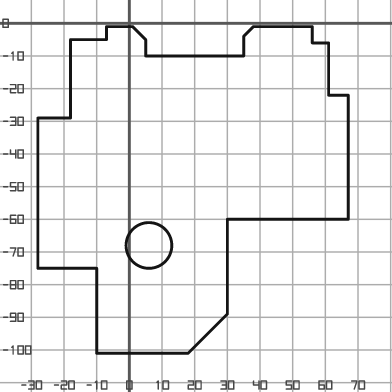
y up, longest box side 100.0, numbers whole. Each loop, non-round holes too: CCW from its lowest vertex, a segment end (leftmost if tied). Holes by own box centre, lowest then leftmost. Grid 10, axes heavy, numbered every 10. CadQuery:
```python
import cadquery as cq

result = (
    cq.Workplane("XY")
    .moveTo(-10.0, -101.0)
    .lineTo(18.0, -101.0)
    .lineTo(30.0, -89.0)
    .lineTo(30.0, -60.0)
    .lineTo(67.0, -60.0)
    .lineTo(67.0, -22.0)
    .lineTo(61.0, -22.0)
    .lineTo(61.0, -6.0)
    .lineTo(56.0, -6.0)
    .lineTo(56.0, -1.0)
    .lineTo(38.0, -1.0)
    .lineTo(35.0, -4.0)
    .lineTo(35.0, -10.0)
    .lineTo(5.0, -10.0)
    .lineTo(5.0, -5.0)
    .lineTo(1.0, -1.0)
    .lineTo(-7.0, -1.0)
    .lineTo(-7.0, -5.0)
    .lineTo(-18.0, -5.0)
    .lineTo(-18.0, -29.0)
    .lineTo(-28.0, -29.0)
    .lineTo(-28.0, -75.0)
    .lineTo(-10.0, -75.0)
    .close()
    .moveTo(6.0, -68.0)
    .circle(7.0)
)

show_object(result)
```